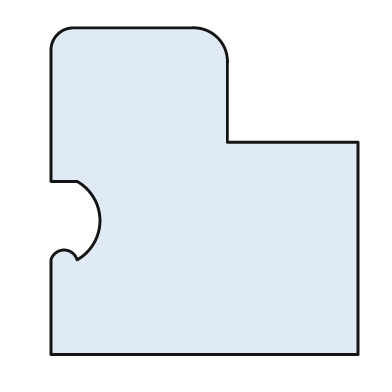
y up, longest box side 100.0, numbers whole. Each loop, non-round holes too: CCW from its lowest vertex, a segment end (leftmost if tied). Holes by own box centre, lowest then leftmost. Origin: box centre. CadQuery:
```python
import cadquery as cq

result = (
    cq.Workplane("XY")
    .moveTo(-47.0, -50.0)
    .lineTo(47.0, -50.0)
    .lineTo(47.0, 15.0)
    .lineTo(7.0, 15.0)
    .lineTo(7.0, 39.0)
    .threePointArc((4.0, 47.0), (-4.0, 50.0))
    .lineTo(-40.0, 50.0)
    .threePointArc((-45.0, 48.0), (-47.0, 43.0))
    .lineTo(-47.0, 3.0)
    .lineTo(-39.0, 3.0)
    .threePointArc((-32.0, -9.0), (-39.0, -21.0))
    .threePointArc((-43.0, -18.0), (-47.0, -21.0))
    .close()
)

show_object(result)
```